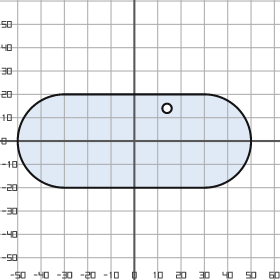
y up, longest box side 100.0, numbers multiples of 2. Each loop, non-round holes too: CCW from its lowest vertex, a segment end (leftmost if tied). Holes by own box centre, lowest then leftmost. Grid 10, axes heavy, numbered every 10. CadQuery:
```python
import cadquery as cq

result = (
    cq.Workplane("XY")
    .moveTo(-30.0, -20.0)
    .lineTo(30.0, -20.0)
    .threePointArc((50.0, 0.0), (30.0, 20.0))
    .lineTo(-30.0, 20.0)
    .threePointArc((-50.0, 0.0), (-30.0, -20.0))
    .close()
    .moveTo(14.0, 14.0)
    .circle(2.0)
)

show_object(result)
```